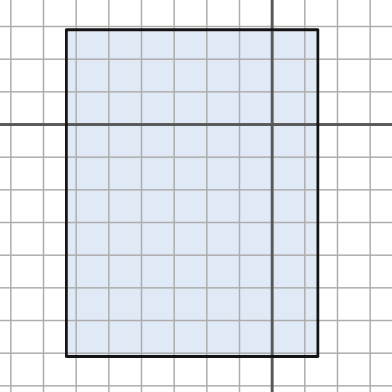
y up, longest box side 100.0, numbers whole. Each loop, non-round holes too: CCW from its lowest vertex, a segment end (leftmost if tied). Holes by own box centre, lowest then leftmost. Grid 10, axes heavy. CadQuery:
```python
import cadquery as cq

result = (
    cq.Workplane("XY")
    .moveTo(-63.0, -71.0)
    .lineTo(14.0, -71.0)
    .lineTo(14.0, 29.0)
    .lineTo(-63.0, 29.0)
    .close()
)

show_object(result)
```